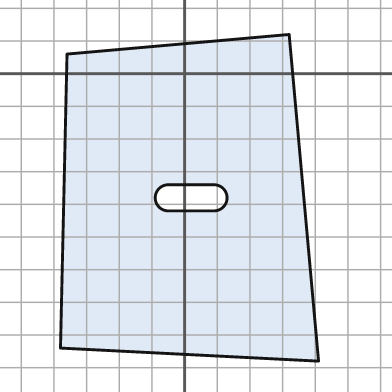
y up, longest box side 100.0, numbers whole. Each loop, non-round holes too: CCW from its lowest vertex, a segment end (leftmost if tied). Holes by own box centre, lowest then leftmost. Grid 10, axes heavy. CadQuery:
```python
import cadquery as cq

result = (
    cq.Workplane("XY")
    .moveTo(41.0, -88.0)
    .lineTo(32.0, 12.0)
    .lineTo(-36.0, 6.0)
    .lineTo(-38.0, -84.0)
    .close()
    .moveTo(-5.0, -42.0)
    .lineTo(9.0, -42.0)
    .threePointArc((13.0, -38.0), (9.0, -34.0))
    .lineTo(-5.0, -34.0)
    .threePointArc((-9.0, -38.0), (-5.0, -42.0))
    .close()
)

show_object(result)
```